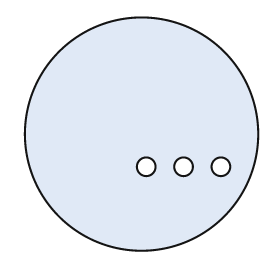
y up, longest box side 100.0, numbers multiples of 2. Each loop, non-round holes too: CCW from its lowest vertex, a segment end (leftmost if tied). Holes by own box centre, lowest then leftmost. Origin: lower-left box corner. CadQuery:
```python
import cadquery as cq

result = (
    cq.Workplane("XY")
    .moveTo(50.0, 50.0)
    .circle(50.0)
    .moveTo(52.0, 36.0)
    .circle(4.0)
    .moveTo(68.0, 36.0)
    .circle(4.0)
    .moveTo(84.0, 36.0)
    .circle(4.0)
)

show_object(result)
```